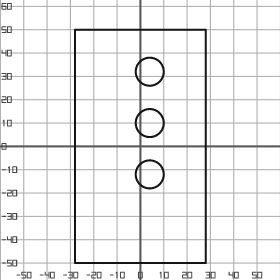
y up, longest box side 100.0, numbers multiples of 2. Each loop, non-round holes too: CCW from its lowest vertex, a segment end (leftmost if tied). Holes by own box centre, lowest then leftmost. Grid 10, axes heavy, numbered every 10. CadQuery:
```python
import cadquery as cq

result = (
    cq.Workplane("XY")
    .moveTo(-28.0, -50.0)
    .lineTo(28.0, -50.0)
    .lineTo(28.0, 50.0)
    .lineTo(-28.0, 50.0)
    .close()
    .moveTo(4.0, -12.0)
    .circle(6.0)
    .moveTo(4.0, 10.0)
    .circle(6.0)
    .moveTo(4.0, 32.0)
    .circle(6.0)
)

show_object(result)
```